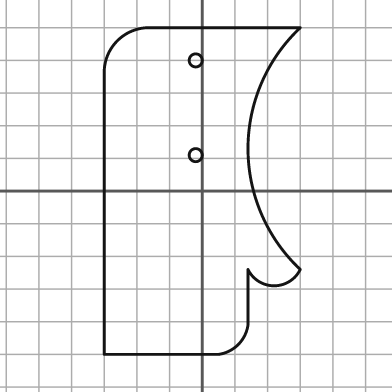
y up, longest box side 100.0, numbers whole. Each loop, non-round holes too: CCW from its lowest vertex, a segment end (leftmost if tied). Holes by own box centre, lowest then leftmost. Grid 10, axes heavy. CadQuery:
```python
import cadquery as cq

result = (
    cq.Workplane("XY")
    .moveTo(-30.0, -50.0)
    .lineTo(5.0, -50.0)
    .threePointArc((11.0, -47.0), (14.0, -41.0))
    .lineTo(14.0, -24.0)
    .threePointArc((22.0, -29.0), (30.0, -24.0))
    .threePointArc((14.0, 13.0), (30.0, 50.0))
    .lineTo(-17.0, 50.0)
    .threePointArc((-26.0, 46.0), (-30.0, 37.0))
    .close()
    .moveTo(-2.0, 11.0)
    .circle(2.0)
    .moveTo(-2.0, 40.0)
    .circle(2.0)
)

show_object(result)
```